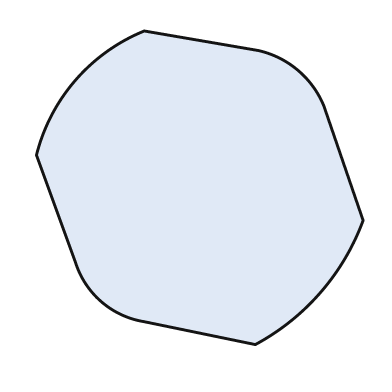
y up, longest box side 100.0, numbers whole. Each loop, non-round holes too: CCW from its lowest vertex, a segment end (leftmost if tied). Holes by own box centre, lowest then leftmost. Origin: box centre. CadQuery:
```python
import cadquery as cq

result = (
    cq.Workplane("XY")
    .moveTo(17.0, -48.0)
    .threePointArc((37.0, -32.0), (50.0, -10.0))
    .lineTo(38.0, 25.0)
    .threePointArc((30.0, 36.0), (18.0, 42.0))
    .lineTo(-17.0, 48.0)
    .threePointArc((-38.0, 33.0), (-50.0, 10.0))
    .lineTo(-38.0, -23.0)
    .threePointArc((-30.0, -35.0), (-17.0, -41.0))
    .close()
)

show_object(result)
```